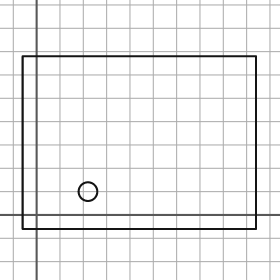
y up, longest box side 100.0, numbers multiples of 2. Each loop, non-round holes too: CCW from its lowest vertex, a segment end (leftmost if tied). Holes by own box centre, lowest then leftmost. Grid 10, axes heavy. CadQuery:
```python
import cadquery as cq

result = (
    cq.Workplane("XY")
    .moveTo(-6.0, -6.0)
    .lineTo(94.0, -6.0)
    .lineTo(94.0, 68.0)
    .lineTo(-6.0, 68.0)
    .close()
    .moveTo(22.0, 10.0)
    .circle(4.0)
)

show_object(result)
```